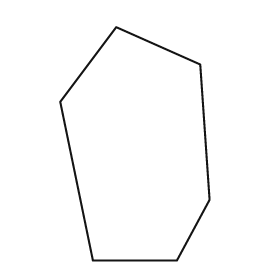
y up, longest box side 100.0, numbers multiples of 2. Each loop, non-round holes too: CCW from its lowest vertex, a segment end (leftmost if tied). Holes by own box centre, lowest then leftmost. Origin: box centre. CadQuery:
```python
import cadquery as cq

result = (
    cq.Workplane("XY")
    .moveTo(-18.0, -50.0)
    .lineTo(18.0, -50.0)
    .lineTo(32.0, -24.0)
    .lineTo(28.0, 34.0)
    .lineTo(-8.0, 50.0)
    .lineTo(-32.0, 18.0)
    .close()
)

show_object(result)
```